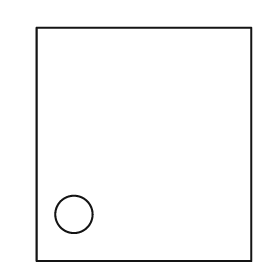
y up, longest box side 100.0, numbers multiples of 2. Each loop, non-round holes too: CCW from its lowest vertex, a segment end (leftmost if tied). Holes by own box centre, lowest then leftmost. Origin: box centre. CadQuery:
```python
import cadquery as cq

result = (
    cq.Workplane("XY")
    .moveTo(-46.0, -50.0)
    .lineTo(46.0, -50.0)
    .lineTo(46.0, 50.0)
    .lineTo(-46.0, 50.0)
    .close()
    .moveTo(-30.0, -30.0)
    .circle(8.0)
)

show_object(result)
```